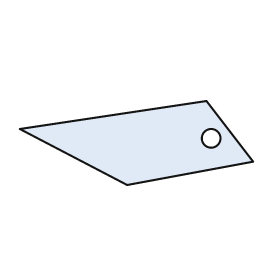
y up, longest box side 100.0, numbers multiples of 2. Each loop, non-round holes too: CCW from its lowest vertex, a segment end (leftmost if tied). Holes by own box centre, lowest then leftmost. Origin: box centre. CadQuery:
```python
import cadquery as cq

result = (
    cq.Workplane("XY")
    .moveTo(-4.0, -18.0)
    .lineTo(50.0, -8.0)
    .lineTo(30.0, 18.0)
    .lineTo(-50.0, 6.0)
    .close()
    .moveTo(32.0, 2.0)
    .circle(4.0)
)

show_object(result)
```